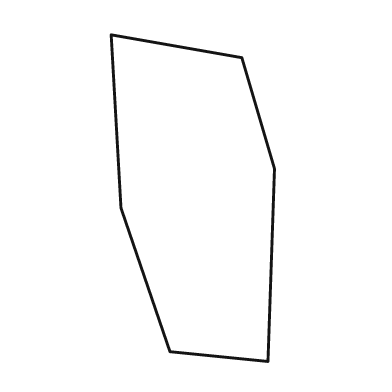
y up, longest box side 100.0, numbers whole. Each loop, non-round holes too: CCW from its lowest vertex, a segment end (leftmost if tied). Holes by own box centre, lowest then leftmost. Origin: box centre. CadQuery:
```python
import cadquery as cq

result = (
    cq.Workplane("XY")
    .moveTo(23.0, -50.0)
    .lineTo(25.0, 9.0)
    .lineTo(15.0, 43.0)
    .lineTo(-25.0, 50.0)
    .lineTo(-22.0, -3.0)
    .lineTo(-7.0, -47.0)
    .close()
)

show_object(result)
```